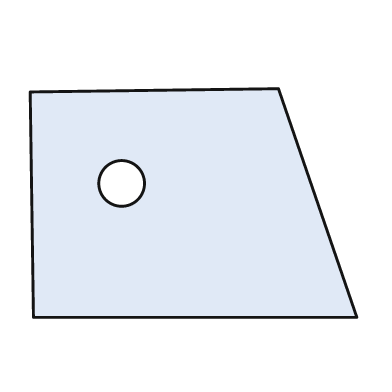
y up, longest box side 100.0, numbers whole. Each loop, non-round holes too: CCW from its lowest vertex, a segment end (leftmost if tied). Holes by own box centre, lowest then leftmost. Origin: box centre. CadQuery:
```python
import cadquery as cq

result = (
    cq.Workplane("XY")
    .moveTo(-49.0, -35.0)
    .lineTo(50.0, -35.0)
    .lineTo(26.0, 35.0)
    .lineTo(-50.0, 34.0)
    .close()
    .moveTo(-22.0, 6.0)
    .circle(7.0)
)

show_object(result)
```